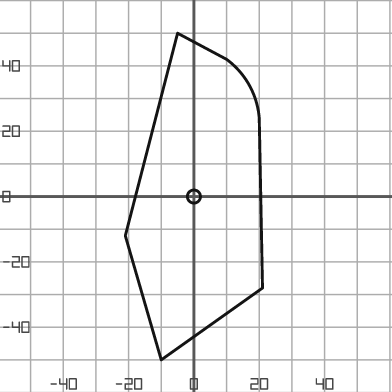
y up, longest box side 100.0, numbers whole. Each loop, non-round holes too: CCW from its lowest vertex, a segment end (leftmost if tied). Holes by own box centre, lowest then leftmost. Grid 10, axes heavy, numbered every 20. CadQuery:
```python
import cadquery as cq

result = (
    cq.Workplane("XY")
    .moveTo(-10.0, -50.0)
    .lineTo(21.0, -28.0)
    .lineTo(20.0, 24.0)
    .threePointArc((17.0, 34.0), (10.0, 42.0))
    .lineTo(-5.0, 50.0)
    .lineTo(-21.0, -12.0)
    .close()
    .moveTo(0.0, 0.0)
    .circle(2.0)
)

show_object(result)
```